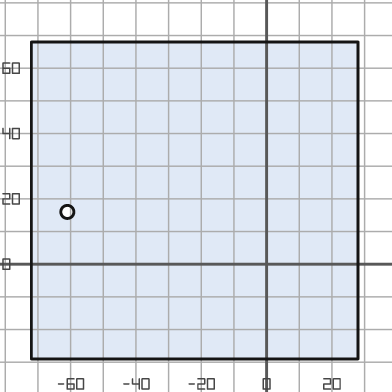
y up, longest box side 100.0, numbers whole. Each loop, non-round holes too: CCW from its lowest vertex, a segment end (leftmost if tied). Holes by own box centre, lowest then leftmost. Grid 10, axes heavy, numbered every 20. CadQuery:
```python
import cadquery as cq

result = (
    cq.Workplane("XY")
    .moveTo(-72.0, -29.0)
    .lineTo(28.0, -29.0)
    .lineTo(28.0, 68.0)
    .lineTo(-72.0, 68.0)
    .close()
    .moveTo(-61.0, 16.0)
    .circle(2.0)
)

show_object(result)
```